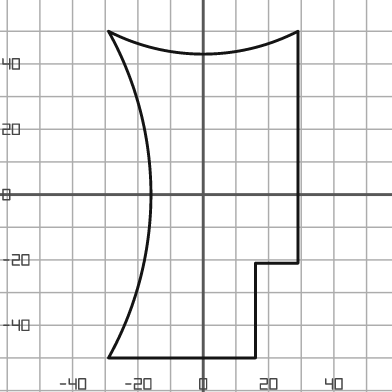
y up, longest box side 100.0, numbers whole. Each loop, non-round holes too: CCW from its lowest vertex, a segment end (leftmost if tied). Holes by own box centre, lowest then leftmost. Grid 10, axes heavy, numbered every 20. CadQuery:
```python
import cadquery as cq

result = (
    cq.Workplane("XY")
    .moveTo(-29.0, -50.0)
    .lineTo(16.0, -50.0)
    .lineTo(16.0, -21.0)
    .lineTo(29.0, -21.0)
    .lineTo(29.0, 50.0)
    .threePointArc((0.0, 43.0), (-29.0, 50.0))
    .threePointArc((-16.0, 0.0), (-29.0, -50.0))
    .close()
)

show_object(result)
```